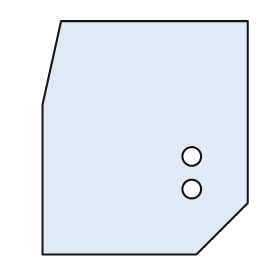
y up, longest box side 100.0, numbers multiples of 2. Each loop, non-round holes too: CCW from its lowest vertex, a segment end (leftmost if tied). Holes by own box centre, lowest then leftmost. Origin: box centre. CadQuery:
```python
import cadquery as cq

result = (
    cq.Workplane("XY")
    .moveTo(-44.0, -50.0)
    .lineTo(22.0, -50.0)
    .lineTo(44.0, -28.0)
    .lineTo(44.0, 50.0)
    .lineTo(-36.0, 50.0)
    .lineTo(-44.0, 14.0)
    .close()
    .moveTo(20.0, -22.0)
    .circle(4.0)
    .moveTo(20.0, -8.0)
    .circle(4.0)
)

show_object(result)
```